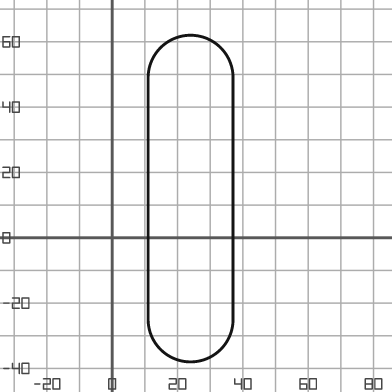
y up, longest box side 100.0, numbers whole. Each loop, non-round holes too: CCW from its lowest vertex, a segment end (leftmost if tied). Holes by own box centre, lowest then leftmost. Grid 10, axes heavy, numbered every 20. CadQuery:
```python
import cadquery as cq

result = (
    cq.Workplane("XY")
    .moveTo(11.0, -25.0)
    .threePointArc((24.0, -38.0), (37.0, -25.0))
    .lineTo(37.0, 49.0)
    .threePointArc((24.0, 62.0), (11.0, 49.0))
    .close()
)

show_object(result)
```